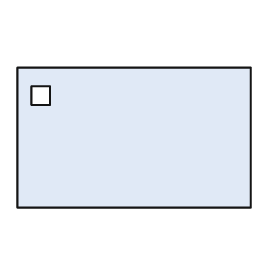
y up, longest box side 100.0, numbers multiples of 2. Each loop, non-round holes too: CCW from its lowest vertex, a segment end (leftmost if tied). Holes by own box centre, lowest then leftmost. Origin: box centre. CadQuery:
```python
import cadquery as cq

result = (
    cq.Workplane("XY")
    .moveTo(-50.0, -30.0)
    .lineTo(50.0, -30.0)
    .lineTo(50.0, 30.0)
    .lineTo(-50.0, 30.0)
    .close()
    .moveTo(-44.0, 14.0)
    .lineTo(-36.0, 14.0)
    .lineTo(-36.0, 22.0)
    .lineTo(-44.0, 22.0)
    .close()
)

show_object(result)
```